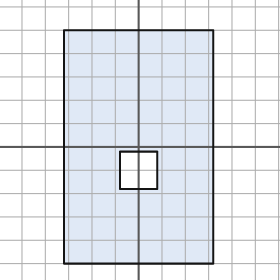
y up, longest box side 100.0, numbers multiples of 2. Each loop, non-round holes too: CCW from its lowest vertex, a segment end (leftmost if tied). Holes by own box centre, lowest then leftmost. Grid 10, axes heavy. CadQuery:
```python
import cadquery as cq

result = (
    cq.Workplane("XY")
    .moveTo(-32.0, -50.0)
    .lineTo(32.0, -50.0)
    .lineTo(32.0, 50.0)
    .lineTo(-32.0, 50.0)
    .close()
    .moveTo(-8.0, -18.0)
    .lineTo(8.0, -18.0)
    .lineTo(8.0, -2.0)
    .lineTo(-8.0, -2.0)
    .close()
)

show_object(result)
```